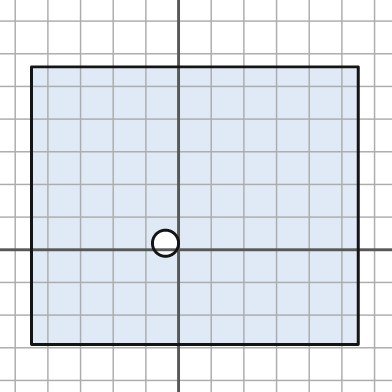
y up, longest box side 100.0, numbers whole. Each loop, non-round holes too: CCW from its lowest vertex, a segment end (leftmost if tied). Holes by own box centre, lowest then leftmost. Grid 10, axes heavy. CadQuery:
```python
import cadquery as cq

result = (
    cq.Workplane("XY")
    .moveTo(-45.0, -29.0)
    .lineTo(55.0, -29.0)
    .lineTo(55.0, 56.0)
    .lineTo(-45.0, 56.0)
    .close()
    .moveTo(-4.0, 2.0)
    .circle(4.0)
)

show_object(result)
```